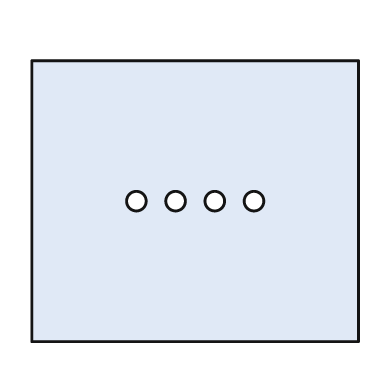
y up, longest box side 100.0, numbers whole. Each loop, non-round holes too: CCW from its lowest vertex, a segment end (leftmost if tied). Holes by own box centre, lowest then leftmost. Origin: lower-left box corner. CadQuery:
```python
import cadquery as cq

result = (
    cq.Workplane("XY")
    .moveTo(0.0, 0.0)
    .lineTo(100.0, 0.0)
    .lineTo(100.0, 86.0)
    .lineTo(0.0, 86.0)
    .close()
    .moveTo(32.0, 43.0)
    .circle(3.0)
    .moveTo(44.0, 43.0)
    .circle(3.0)
    .moveTo(56.0, 43.0)
    .circle(3.0)
    .moveTo(68.0, 43.0)
    .circle(3.0)
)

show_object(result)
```